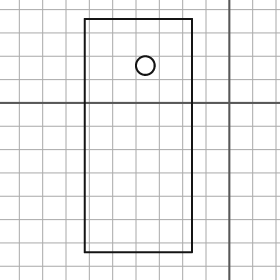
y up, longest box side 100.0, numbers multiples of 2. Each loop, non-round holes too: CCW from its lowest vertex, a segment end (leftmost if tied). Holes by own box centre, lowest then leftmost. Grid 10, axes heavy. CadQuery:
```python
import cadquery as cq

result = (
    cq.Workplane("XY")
    .moveTo(-62.0, -64.0)
    .lineTo(-16.0, -64.0)
    .lineTo(-16.0, 36.0)
    .lineTo(-62.0, 36.0)
    .close()
    .moveTo(-36.0, 16.0)
    .circle(4.0)
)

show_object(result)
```